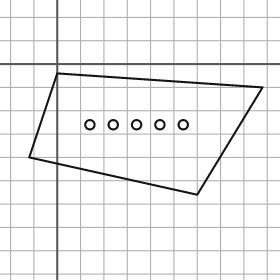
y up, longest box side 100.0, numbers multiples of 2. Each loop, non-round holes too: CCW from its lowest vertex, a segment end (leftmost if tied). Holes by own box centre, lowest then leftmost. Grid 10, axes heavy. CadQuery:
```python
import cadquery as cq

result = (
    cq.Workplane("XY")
    .moveTo(60.0, -56.0)
    .lineTo(88.0, -10.0)
    .lineTo(0.0, -4.0)
    .lineTo(-12.0, -40.0)
    .close()
    .moveTo(14.0, -26.0)
    .circle(2.0)
    .moveTo(24.0, -26.0)
    .circle(2.0)
    .moveTo(34.0, -26.0)
    .circle(2.0)
    .moveTo(44.0, -26.0)
    .circle(2.0)
    .moveTo(54.0, -26.0)
    .circle(2.0)
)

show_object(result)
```